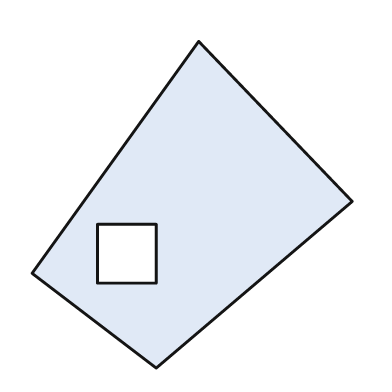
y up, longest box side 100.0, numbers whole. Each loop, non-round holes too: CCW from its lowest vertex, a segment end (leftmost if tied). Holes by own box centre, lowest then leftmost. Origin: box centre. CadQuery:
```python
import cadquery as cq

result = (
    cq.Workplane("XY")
    .moveTo(-11.0, -50.0)
    .lineTo(49.0, 1.0)
    .lineTo(2.0, 50.0)
    .lineTo(-49.0, -21.0)
    .close()
    .moveTo(-29.0, -24.0)
    .lineTo(-11.0, -24.0)
    .lineTo(-11.0, -6.0)
    .lineTo(-29.0, -6.0)
    .close()
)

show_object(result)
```